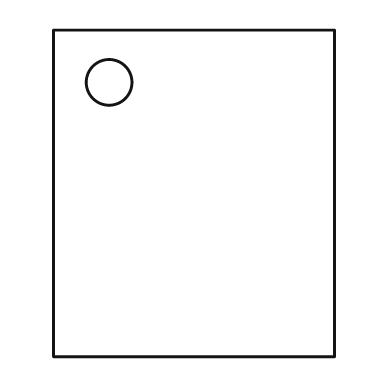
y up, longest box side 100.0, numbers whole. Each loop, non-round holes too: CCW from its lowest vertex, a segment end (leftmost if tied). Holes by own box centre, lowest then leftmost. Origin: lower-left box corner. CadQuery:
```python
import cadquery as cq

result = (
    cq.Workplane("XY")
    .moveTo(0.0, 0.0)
    .lineTo(86.0, 0.0)
    .lineTo(86.0, 100.0)
    .lineTo(0.0, 100.0)
    .close()
    .moveTo(17.0, 84.0)
    .circle(7.0)
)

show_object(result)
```